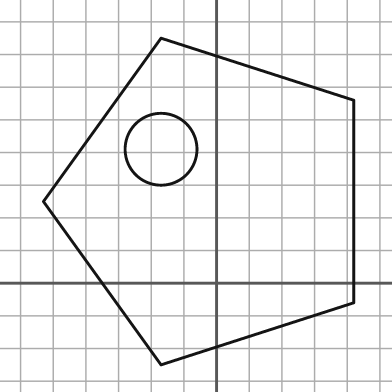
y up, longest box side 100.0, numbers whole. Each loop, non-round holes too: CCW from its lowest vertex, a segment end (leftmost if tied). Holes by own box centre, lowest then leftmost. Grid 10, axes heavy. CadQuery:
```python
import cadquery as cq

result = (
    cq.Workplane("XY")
    .moveTo(-17.0, -25.0)
    .lineTo(42.0, -6.0)
    .lineTo(42.0, 56.0)
    .lineTo(-17.0, 75.0)
    .lineTo(-53.0, 25.0)
    .close()
    .moveTo(-17.0, 41.0)
    .circle(11.0)
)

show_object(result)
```